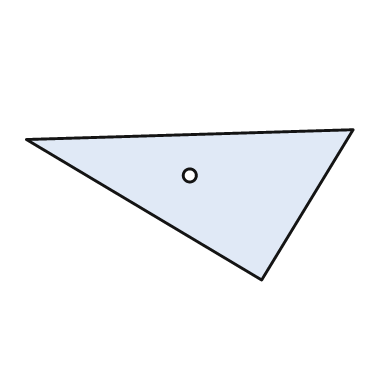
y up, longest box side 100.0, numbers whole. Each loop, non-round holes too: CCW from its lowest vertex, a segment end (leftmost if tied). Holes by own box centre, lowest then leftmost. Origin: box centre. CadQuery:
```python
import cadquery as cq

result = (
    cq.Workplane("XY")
    .moveTo(22.0, -23.0)
    .lineTo(50.0, 23.0)
    .lineTo(-50.0, 20.0)
    .close()
    .moveTo(0.0, 9.0)
    .circle(2.0)
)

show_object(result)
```